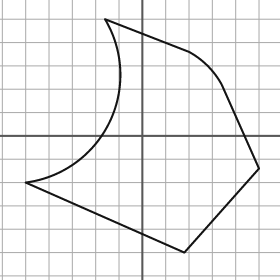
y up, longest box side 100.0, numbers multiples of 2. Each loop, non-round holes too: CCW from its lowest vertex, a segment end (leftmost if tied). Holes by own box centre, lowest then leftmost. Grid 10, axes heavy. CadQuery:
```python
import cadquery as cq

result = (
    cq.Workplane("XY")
    .moveTo(18.0, -50.0)
    .lineTo(50.0, -14.0)
    .lineTo(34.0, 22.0)
    .threePointArc((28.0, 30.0), (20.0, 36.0))
    .lineTo(-16.0, 50.0)
    .threePointArc((-14.0, 6.0), (-50.0, -20.0))
    .close()
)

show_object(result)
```